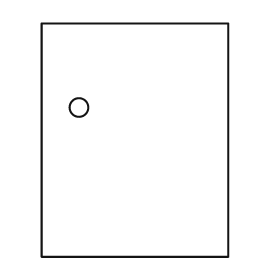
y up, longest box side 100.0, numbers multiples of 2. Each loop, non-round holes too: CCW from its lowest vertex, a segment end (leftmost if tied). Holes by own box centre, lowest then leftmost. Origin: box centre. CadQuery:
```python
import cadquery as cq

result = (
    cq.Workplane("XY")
    .moveTo(-40.0, -50.0)
    .lineTo(40.0, -50.0)
    .lineTo(40.0, 50.0)
    .lineTo(-40.0, 50.0)
    .close()
    .moveTo(-24.0, 14.0)
    .circle(4.0)
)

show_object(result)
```